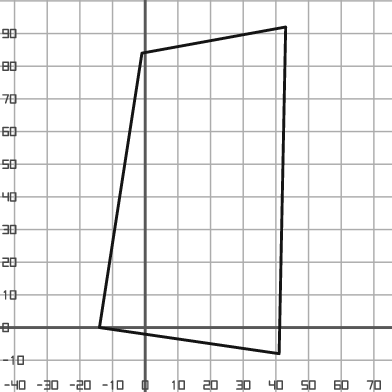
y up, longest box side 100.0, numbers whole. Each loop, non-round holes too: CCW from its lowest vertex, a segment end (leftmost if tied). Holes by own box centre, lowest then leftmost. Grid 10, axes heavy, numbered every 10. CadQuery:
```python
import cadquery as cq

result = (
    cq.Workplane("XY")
    .moveTo(41.0, -8.0)
    .lineTo(43.0, 92.0)
    .lineTo(-1.0, 84.0)
    .lineTo(-14.0, 0.0)
    .close()
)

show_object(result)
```